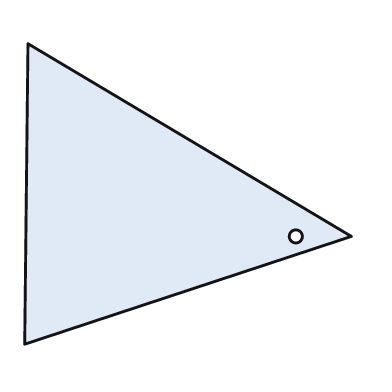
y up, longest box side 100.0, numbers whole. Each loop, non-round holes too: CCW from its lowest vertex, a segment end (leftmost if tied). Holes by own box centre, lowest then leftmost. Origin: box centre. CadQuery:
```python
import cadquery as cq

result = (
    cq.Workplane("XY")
    .moveTo(-50.0, -46.0)
    .lineTo(50.0, -13.0)
    .lineTo(-49.0, 46.0)
    .close()
    .moveTo(33.0, -13.0)
    .circle(2.0)
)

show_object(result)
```